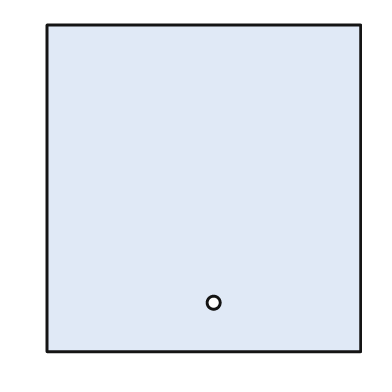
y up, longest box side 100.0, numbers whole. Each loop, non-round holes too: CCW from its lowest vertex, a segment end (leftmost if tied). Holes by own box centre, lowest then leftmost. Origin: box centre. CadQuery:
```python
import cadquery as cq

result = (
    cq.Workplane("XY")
    .moveTo(-48.0, -50.0)
    .lineTo(48.0, -50.0)
    .lineTo(48.0, 50.0)
    .lineTo(-48.0, 50.0)
    .close()
    .moveTo(3.0, -35.0)
    .circle(2.0)
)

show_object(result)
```